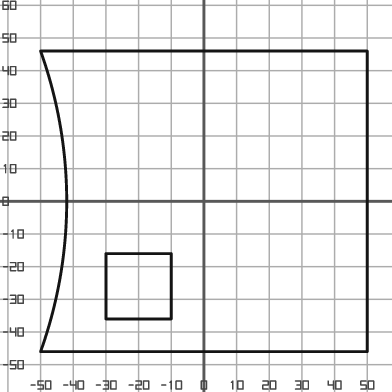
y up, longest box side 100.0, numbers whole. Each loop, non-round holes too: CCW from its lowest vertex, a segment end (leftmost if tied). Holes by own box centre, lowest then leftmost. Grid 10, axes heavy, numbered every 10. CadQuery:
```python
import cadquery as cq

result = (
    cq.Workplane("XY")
    .moveTo(-50.0, -46.0)
    .lineTo(50.0, -46.0)
    .lineTo(50.0, 46.0)
    .lineTo(-50.0, 46.0)
    .threePointArc((-42.0, 0.0), (-50.0, -46.0))
    .close()
    .moveTo(-30.0, -36.0)
    .lineTo(-10.0, -36.0)
    .lineTo(-10.0, -16.0)
    .lineTo(-30.0, -16.0)
    .close()
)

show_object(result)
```